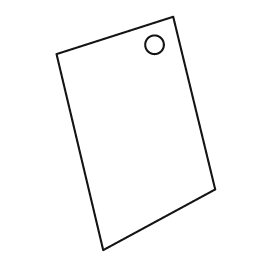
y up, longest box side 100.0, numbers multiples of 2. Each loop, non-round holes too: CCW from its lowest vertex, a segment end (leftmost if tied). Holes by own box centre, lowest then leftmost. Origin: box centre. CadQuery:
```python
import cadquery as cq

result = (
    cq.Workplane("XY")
    .moveTo(-14.0, -50.0)
    .lineTo(34.0, -24.0)
    .lineTo(16.0, 50.0)
    .lineTo(-34.0, 34.0)
    .close()
    .moveTo(8.0, 38.0)
    .circle(4.0)
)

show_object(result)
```